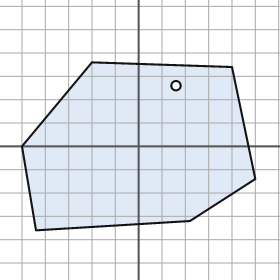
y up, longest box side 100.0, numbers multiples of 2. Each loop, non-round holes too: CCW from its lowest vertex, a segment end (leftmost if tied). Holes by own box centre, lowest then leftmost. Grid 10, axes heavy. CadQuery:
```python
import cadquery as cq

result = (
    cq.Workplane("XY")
    .moveTo(-44.0, -36.0)
    .lineTo(22.0, -32.0)
    .lineTo(50.0, -14.0)
    .lineTo(40.0, 34.0)
    .lineTo(-20.0, 36.0)
    .lineTo(-50.0, 0.0)
    .close()
    .moveTo(16.0, 26.0)
    .circle(2.0)
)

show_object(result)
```